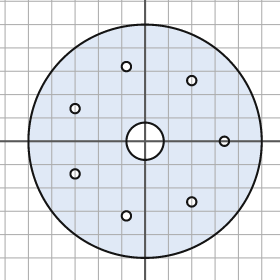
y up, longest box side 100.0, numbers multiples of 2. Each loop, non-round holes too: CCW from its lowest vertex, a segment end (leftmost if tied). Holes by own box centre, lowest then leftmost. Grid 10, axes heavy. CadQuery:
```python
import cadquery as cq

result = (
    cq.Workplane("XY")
    .moveTo(0.0, 0.0)
    .circle(50.0)
    .moveTo(-8.0, -32.0)
    .circle(2.0)
    .moveTo(20.0, -26.0)
    .circle(2.0)
    .moveTo(-30.0, -14.0)
    .circle(2.0)
    .moveTo(0.0, 0.0)
    .circle(8.0)
    .moveTo(34.0, 0.0)
    .circle(2.0)
    .moveTo(-30.0, 14.0)
    .circle(2.0)
    .moveTo(20.0, 26.0)
    .circle(2.0)
    .moveTo(-8.0, 32.0)
    .circle(2.0)
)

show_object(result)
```